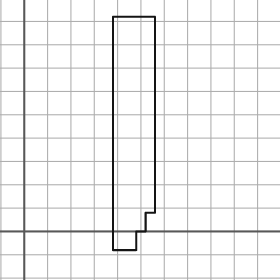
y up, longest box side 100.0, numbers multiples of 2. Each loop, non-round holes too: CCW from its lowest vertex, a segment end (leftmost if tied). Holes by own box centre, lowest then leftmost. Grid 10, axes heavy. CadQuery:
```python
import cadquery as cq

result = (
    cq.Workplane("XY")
    .moveTo(38.0, -8.0)
    .lineTo(48.0, -8.0)
    .lineTo(48.0, 0.0)
    .lineTo(52.0, 0.0)
    .lineTo(52.0, 8.0)
    .lineTo(56.0, 8.0)
    .lineTo(56.0, 92.0)
    .lineTo(38.0, 92.0)
    .close()
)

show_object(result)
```